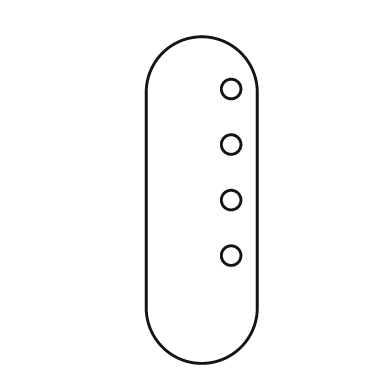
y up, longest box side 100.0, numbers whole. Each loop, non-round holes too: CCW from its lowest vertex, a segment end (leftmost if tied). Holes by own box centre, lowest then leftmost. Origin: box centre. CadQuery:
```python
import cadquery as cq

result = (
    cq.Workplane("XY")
    .moveTo(-17.0, -33.0)
    .threePointArc((0.0, -50.0), (17.0, -33.0))
    .lineTo(17.0, 33.0)
    .threePointArc((0.0, 50.0), (-17.0, 33.0))
    .close()
    .moveTo(9.0, -17.0)
    .circle(3.0)
    .moveTo(9.0, 0.0)
    .circle(3.0)
    .moveTo(9.0, 17.0)
    .circle(3.0)
    .moveTo(9.0, 34.0)
    .circle(3.0)
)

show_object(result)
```